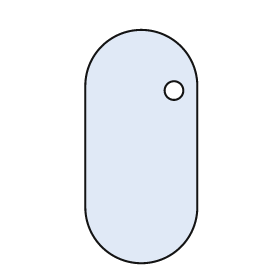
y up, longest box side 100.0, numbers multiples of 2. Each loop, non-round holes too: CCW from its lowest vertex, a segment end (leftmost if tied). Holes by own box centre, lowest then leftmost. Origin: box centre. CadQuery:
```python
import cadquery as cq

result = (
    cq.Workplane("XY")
    .moveTo(-24.0, -26.0)
    .threePointArc((0.0, -50.0), (24.0, -26.0))
    .lineTo(24.0, 26.0)
    .threePointArc((0.0, 50.0), (-24.0, 26.0))
    .close()
    .moveTo(14.0, 24.0)
    .circle(4.0)
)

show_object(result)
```